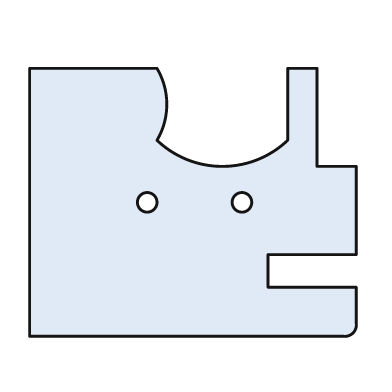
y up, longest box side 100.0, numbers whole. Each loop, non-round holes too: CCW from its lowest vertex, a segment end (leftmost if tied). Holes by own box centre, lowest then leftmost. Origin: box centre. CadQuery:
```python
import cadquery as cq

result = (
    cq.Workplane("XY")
    .moveTo(-50.0, -41.0)
    .lineTo(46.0, -41.0)
    .threePointArc((49.0, -40.0), (50.0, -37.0))
    .lineTo(50.0, -26.0)
    .lineTo(23.0, -26.0)
    .lineTo(23.0, -16.0)
    .lineTo(50.0, -16.0)
    .lineTo(50.0, 11.0)
    .lineTo(38.0, 11.0)
    .lineTo(38.0, 41.0)
    .lineTo(29.0, 41.0)
    .lineTo(29.0, 19.0)
    .threePointArc((9.0, 11.0), (-11.0, 19.0))
    .threePointArc((-8.0, 30.0), (-11.0, 41.0))
    .lineTo(-50.0, 41.0)
    .close()
    .moveTo(-14.0, 0.0)
    .circle(3.0)
    .moveTo(15.0, 0.0)
    .circle(3.0)
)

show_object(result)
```